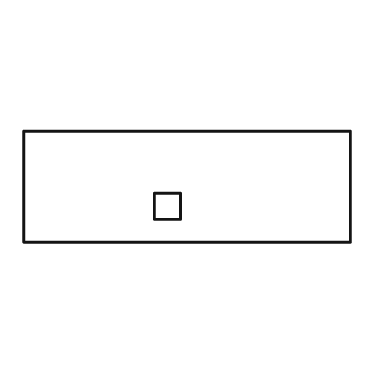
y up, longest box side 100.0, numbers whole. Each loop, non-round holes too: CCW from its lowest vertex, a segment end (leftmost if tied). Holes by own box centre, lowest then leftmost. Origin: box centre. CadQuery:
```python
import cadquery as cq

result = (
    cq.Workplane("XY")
    .moveTo(-50.0, -17.0)
    .lineTo(50.0, -17.0)
    .lineTo(50.0, 17.0)
    .lineTo(-50.0, 17.0)
    .close()
    .moveTo(-10.0, -10.0)
    .lineTo(-2.0, -10.0)
    .lineTo(-2.0, -2.0)
    .lineTo(-10.0, -2.0)
    .close()
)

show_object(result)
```